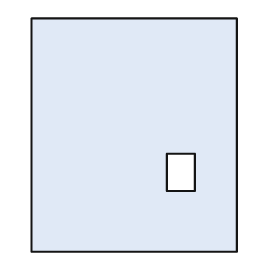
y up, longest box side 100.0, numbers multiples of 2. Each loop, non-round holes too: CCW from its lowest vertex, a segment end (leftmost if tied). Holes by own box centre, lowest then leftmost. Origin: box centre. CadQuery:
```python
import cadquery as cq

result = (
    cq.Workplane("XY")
    .moveTo(-44.0, -50.0)
    .lineTo(44.0, -50.0)
    .lineTo(44.0, 50.0)
    .lineTo(-44.0, 50.0)
    .close()
    .moveTo(14.0, -24.0)
    .lineTo(26.0, -24.0)
    .lineTo(26.0, -8.0)
    .lineTo(14.0, -8.0)
    .close()
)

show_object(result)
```